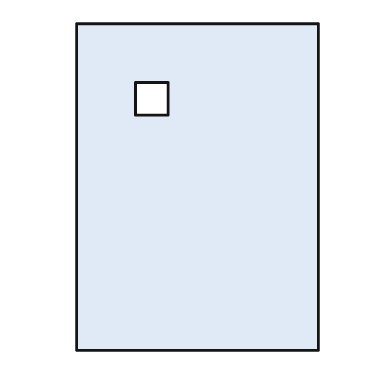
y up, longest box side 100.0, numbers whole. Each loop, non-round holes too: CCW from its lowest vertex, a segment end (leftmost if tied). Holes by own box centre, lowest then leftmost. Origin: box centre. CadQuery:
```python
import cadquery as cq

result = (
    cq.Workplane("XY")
    .moveTo(-37.0, -50.0)
    .lineTo(37.0, -50.0)
    .lineTo(37.0, 50.0)
    .lineTo(-37.0, 50.0)
    .close()
    .moveTo(-19.0, 22.0)
    .lineTo(-9.0, 22.0)
    .lineTo(-9.0, 32.0)
    .lineTo(-19.0, 32.0)
    .close()
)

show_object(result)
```